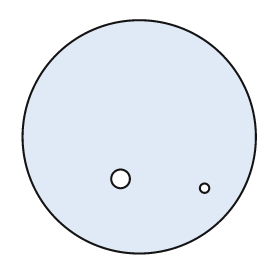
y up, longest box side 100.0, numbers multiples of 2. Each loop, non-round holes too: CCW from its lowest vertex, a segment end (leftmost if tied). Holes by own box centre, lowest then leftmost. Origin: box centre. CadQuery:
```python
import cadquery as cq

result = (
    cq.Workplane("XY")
    .moveTo(0.0, 0.0)
    .circle(50.0)
    .moveTo(28.0, -22.0)
    .circle(2.0)
    .moveTo(-8.0, -18.0)
    .circle(4.0)
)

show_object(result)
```